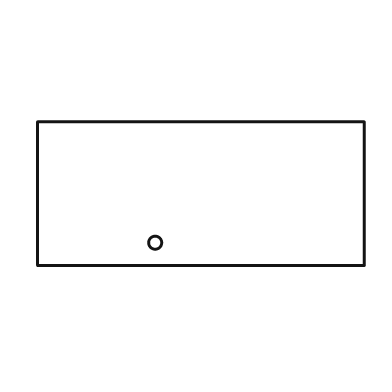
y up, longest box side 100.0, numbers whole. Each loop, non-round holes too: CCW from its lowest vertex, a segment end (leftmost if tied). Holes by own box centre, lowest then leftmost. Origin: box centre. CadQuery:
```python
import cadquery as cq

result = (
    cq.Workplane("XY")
    .moveTo(-50.0, -22.0)
    .lineTo(50.0, -22.0)
    .lineTo(50.0, 22.0)
    .lineTo(-50.0, 22.0)
    .close()
    .moveTo(-14.0, -15.0)
    .circle(2.0)
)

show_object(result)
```